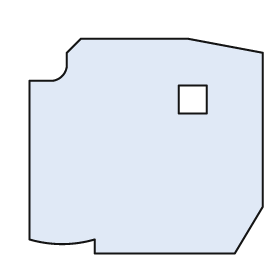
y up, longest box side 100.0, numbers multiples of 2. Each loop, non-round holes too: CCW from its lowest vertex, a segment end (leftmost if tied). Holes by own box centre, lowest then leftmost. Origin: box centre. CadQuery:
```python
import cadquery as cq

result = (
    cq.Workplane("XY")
    .moveTo(-22.0, -46.0)
    .lineTo(38.0, -46.0)
    .lineTo(50.0, -26.0)
    .lineTo(50.0, 40.0)
    .lineTo(18.0, 46.0)
    .lineTo(-28.0, 46.0)
    .lineTo(-34.0, 40.0)
    .lineTo(-34.0, 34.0)
    .threePointArc((-36.0, 30.0), (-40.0, 28.0))
    .lineTo(-50.0, 28.0)
    .lineTo(-50.0, -40.0)
    .threePointArc((-36.0, -42.0), (-22.0, -40.0))
    .close()
    .moveTo(14.0, 14.0)
    .lineTo(26.0, 14.0)
    .lineTo(26.0, 26.0)
    .lineTo(14.0, 26.0)
    .close()
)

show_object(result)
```